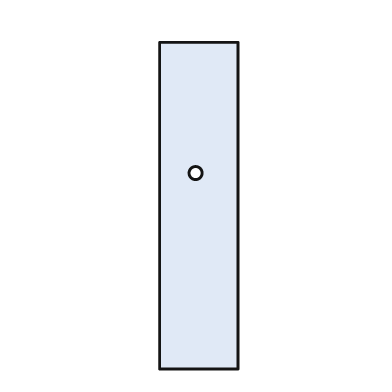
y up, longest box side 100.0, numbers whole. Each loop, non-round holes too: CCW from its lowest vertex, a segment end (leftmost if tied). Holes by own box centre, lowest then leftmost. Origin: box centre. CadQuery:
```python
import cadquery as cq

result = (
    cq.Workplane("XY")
    .moveTo(-12.0, -50.0)
    .lineTo(12.0, -50.0)
    .lineTo(12.0, 50.0)
    .lineTo(-12.0, 50.0)
    .close()
    .moveTo(-1.0, 10.0)
    .circle(2.0)
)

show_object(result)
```